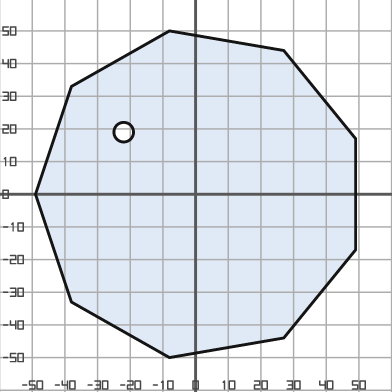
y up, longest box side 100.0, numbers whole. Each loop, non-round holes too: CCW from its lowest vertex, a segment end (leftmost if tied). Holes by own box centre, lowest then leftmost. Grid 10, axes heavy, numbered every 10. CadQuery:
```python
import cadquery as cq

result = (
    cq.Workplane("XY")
    .moveTo(-8.0, -50.0)
    .lineTo(27.0, -44.0)
    .lineTo(49.0, -17.0)
    .lineTo(49.0, 17.0)
    .lineTo(27.0, 44.0)
    .lineTo(-8.0, 50.0)
    .lineTo(-38.0, 33.0)
    .lineTo(-49.0, 0.0)
    .lineTo(-38.0, -33.0)
    .close()
    .moveTo(-22.0, 19.0)
    .circle(3.0)
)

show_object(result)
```